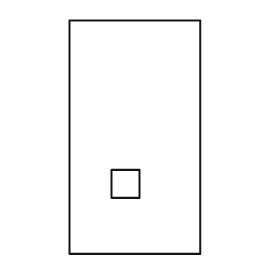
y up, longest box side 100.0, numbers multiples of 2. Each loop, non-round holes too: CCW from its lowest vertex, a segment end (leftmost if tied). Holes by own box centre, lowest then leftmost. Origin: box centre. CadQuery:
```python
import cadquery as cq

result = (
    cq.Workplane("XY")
    .moveTo(-28.0, -50.0)
    .lineTo(28.0, -50.0)
    .lineTo(28.0, 50.0)
    .lineTo(-28.0, 50.0)
    .close()
    .moveTo(-10.0, -26.0)
    .lineTo(2.0, -26.0)
    .lineTo(2.0, -14.0)
    .lineTo(-10.0, -14.0)
    .close()
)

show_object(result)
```